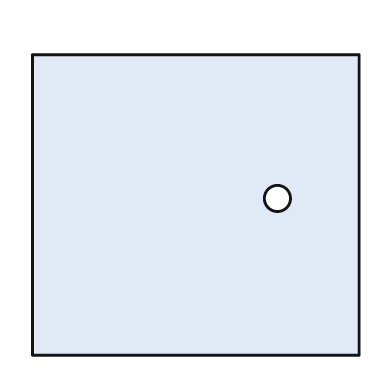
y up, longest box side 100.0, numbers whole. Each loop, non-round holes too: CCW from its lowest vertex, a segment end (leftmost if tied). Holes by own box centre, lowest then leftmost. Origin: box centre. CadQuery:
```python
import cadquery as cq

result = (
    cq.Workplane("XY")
    .moveTo(-50.0, -46.0)
    .lineTo(50.0, -46.0)
    .lineTo(50.0, 46.0)
    .lineTo(-50.0, 46.0)
    .close()
    .moveTo(25.0, 2.0)
    .circle(4.0)
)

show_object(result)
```